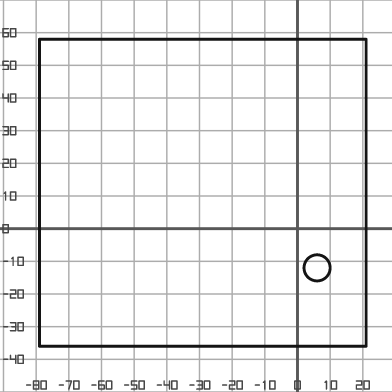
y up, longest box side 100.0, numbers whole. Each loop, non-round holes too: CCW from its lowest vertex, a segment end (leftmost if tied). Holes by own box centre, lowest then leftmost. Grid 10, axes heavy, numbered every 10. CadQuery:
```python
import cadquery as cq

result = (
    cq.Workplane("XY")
    .moveTo(-79.0, -36.0)
    .lineTo(21.0, -36.0)
    .lineTo(21.0, 58.0)
    .lineTo(-79.0, 58.0)
    .close()
    .moveTo(6.0, -12.0)
    .circle(4.0)
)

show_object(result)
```